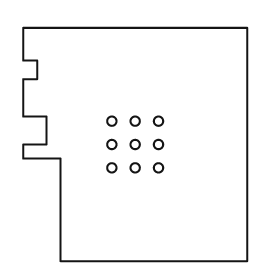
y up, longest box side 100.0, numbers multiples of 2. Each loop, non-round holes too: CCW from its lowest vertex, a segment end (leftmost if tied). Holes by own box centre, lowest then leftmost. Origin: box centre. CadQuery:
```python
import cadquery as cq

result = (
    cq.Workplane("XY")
    .moveTo(-32.0, -50.0)
    .lineTo(48.0, -50.0)
    .lineTo(48.0, 50.0)
    .lineTo(-48.0, 50.0)
    .lineTo(-48.0, 36.0)
    .lineTo(-42.0, 36.0)
    .lineTo(-42.0, 28.0)
    .lineTo(-48.0, 28.0)
    .lineTo(-48.0, 12.0)
    .lineTo(-38.0, 12.0)
    .lineTo(-38.0, 0.0)
    .lineTo(-48.0, 0.0)
    .lineTo(-48.0, -6.0)
    .lineTo(-32.0, -6.0)
    .close()
    .moveTo(-10.0, -10.0)
    .circle(2.0)
    .moveTo(0.0, -10.0)
    .circle(2.0)
    .moveTo(10.0, -10.0)
    .circle(2.0)
    .moveTo(-10.0, 0.0)
    .circle(2.0)
    .moveTo(0.0, 0.0)
    .circle(2.0)
    .moveTo(10.0, 0.0)
    .circle(2.0)
    .moveTo(-10.0, 10.0)
    .circle(2.0)
    .moveTo(0.0, 10.0)
    .circle(2.0)
    .moveTo(10.0, 10.0)
    .circle(2.0)
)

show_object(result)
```